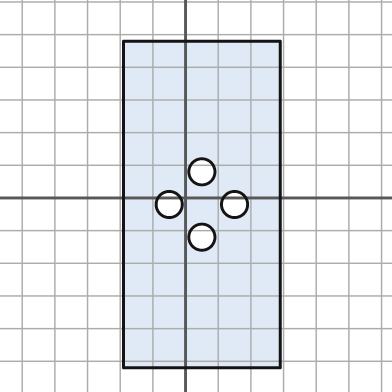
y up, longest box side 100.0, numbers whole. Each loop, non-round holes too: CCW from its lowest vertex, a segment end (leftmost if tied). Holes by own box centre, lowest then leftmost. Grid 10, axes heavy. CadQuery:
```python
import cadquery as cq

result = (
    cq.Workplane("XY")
    .moveTo(-19.0, -52.0)
    .lineTo(29.0, -52.0)
    .lineTo(29.0, 48.0)
    .lineTo(-19.0, 48.0)
    .close()
    .moveTo(5.0, -12.0)
    .circle(4.0)
    .moveTo(-5.0, -2.0)
    .circle(4.0)
    .moveTo(15.0, -2.0)
    .circle(4.0)
    .moveTo(5.0, 8.0)
    .circle(4.0)
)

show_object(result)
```